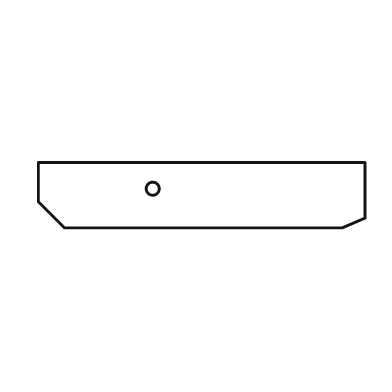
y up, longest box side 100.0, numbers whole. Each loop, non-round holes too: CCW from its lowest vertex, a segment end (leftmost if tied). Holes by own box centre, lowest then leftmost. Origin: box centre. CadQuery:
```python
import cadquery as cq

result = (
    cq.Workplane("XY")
    .moveTo(-42.0, -10.0)
    .lineTo(43.0, -10.0)
    .lineTo(50.0, -7.0)
    .lineTo(50.0, 10.0)
    .lineTo(-50.0, 10.0)
    .lineTo(-50.0, -2.0)
    .close()
    .moveTo(-15.0, 2.0)
    .circle(2.0)
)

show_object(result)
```